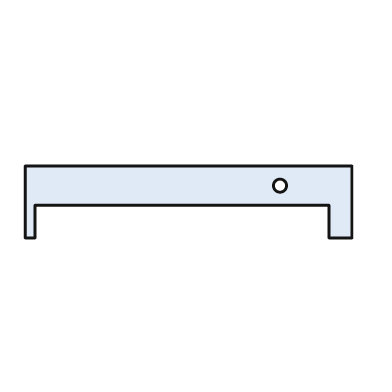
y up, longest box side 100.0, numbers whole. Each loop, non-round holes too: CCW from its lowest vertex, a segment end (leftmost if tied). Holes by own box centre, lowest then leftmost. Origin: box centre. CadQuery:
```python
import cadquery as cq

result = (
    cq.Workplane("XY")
    .moveTo(-50.0, -11.0)
    .lineTo(-47.0, -11.0)
    .lineTo(-47.0, -1.0)
    .lineTo(43.0, -1.0)
    .lineTo(43.0, -11.0)
    .lineTo(50.0, -11.0)
    .lineTo(50.0, 11.0)
    .lineTo(-50.0, 11.0)
    .close()
    .moveTo(28.0, 5.0)
    .circle(2.0)
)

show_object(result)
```